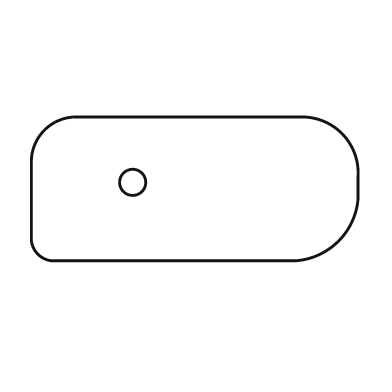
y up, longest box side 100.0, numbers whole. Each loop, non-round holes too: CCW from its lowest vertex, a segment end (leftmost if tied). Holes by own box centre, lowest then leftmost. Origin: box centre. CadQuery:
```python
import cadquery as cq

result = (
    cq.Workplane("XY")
    .moveTo(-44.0, -22.0)
    .lineTo(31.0, -22.0)
    .threePointArc((44.0, -16.0), (50.0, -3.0))
    .lineTo(50.0, 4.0)
    .threePointArc((45.0, 17.0), (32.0, 22.0))
    .lineTo(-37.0, 22.0)
    .threePointArc((-46.0, 18.0), (-50.0, 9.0))
    .lineTo(-50.0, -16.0)
    .threePointArc((-48.0, -20.0), (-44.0, -22.0))
    .close()
    .moveTo(-19.0, 2.0)
    .circle(4.0)
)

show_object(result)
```